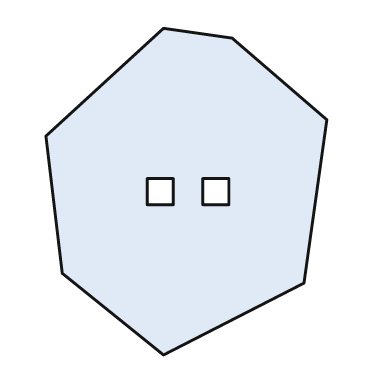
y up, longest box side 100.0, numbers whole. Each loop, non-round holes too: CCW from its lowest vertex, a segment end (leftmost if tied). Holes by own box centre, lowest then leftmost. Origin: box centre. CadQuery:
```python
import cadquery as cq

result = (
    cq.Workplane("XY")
    .moveTo(-7.0, -50.0)
    .lineTo(36.0, -28.0)
    .lineTo(43.0, 22.0)
    .lineTo(14.0, 47.0)
    .lineTo(-7.0, 50.0)
    .lineTo(-43.0, 17.0)
    .lineTo(-38.0, -25.0)
    .close()
    .moveTo(-12.0, -4.0)
    .lineTo(-4.0, -4.0)
    .lineTo(-4.0, 4.0)
    .lineTo(-12.0, 4.0)
    .close()
    .moveTo(5.0, -4.0)
    .lineTo(13.0, -4.0)
    .lineTo(13.0, 4.0)
    .lineTo(5.0, 4.0)
    .close()
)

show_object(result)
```